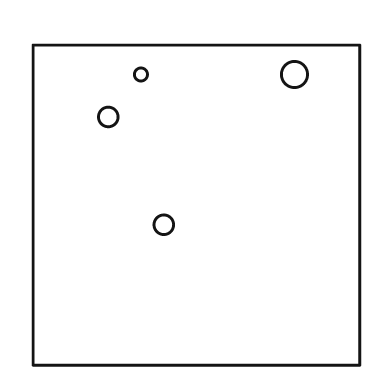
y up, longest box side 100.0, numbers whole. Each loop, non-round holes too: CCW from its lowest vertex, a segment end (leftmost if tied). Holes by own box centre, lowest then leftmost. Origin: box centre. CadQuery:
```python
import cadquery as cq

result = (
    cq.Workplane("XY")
    .moveTo(-50.0, -49.0)
    .lineTo(50.0, -49.0)
    .lineTo(50.0, 49.0)
    .lineTo(-50.0, 49.0)
    .close()
    .moveTo(-10.0, -6.0)
    .circle(3.0)
    .moveTo(-27.0, 27.0)
    .circle(3.0)
    .moveTo(-17.0, 40.0)
    .circle(2.0)
    .moveTo(30.0, 40.0)
    .circle(4.0)
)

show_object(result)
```